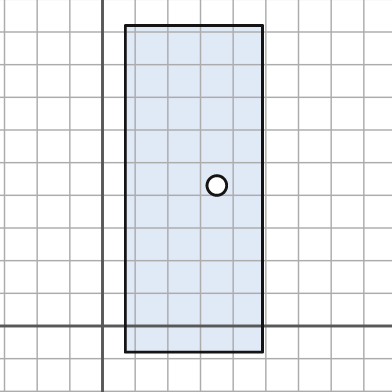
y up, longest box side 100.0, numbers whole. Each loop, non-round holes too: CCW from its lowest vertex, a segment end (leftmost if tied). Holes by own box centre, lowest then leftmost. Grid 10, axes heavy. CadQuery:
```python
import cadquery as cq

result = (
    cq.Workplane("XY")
    .moveTo(7.0, -8.0)
    .lineTo(49.0, -8.0)
    .lineTo(49.0, 92.0)
    .lineTo(7.0, 92.0)
    .close()
    .moveTo(35.0, 43.0)
    .circle(3.0)
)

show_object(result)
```